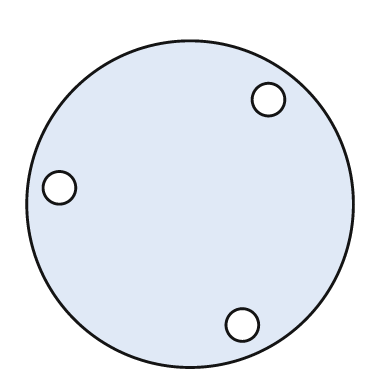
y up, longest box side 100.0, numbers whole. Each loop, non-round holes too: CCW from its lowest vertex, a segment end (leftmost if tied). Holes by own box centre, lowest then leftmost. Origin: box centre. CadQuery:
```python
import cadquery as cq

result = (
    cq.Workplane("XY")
    .moveTo(0.0, 0.0)
    .circle(50.0)
    .moveTo(16.0, -37.0)
    .circle(5.0)
    .moveTo(-40.0, 5.0)
    .circle(5.0)
    .moveTo(24.0, 32.0)
    .circle(5.0)
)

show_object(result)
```